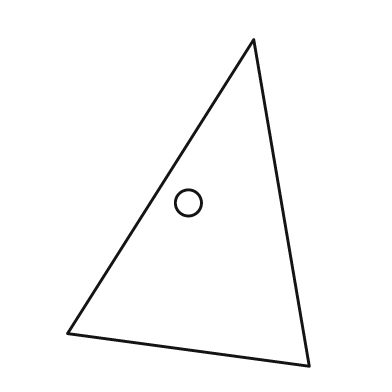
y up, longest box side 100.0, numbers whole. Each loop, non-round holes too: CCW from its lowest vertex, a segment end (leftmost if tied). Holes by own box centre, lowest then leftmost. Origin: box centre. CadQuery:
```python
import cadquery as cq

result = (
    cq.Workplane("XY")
    .moveTo(37.0, -50.0)
    .lineTo(20.0, 50.0)
    .lineTo(-37.0, -40.0)
    .close()
    .moveTo(0.0, 0.0)
    .circle(4.0)
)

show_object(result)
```